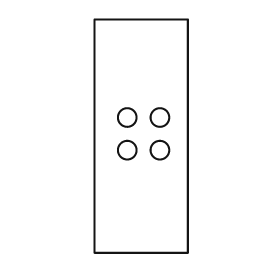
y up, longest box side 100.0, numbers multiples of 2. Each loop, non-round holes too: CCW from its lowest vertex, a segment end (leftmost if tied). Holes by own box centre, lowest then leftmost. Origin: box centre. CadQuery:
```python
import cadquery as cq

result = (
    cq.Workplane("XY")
    .moveTo(-20.0, -50.0)
    .lineTo(20.0, -50.0)
    .lineTo(20.0, 50.0)
    .lineTo(-20.0, 50.0)
    .close()
    .moveTo(-6.0, -6.0)
    .circle(4.0)
    .moveTo(8.0, -6.0)
    .circle(4.0)
    .moveTo(-6.0, 8.0)
    .circle(4.0)
    .moveTo(8.0, 8.0)
    .circle(4.0)
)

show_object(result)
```